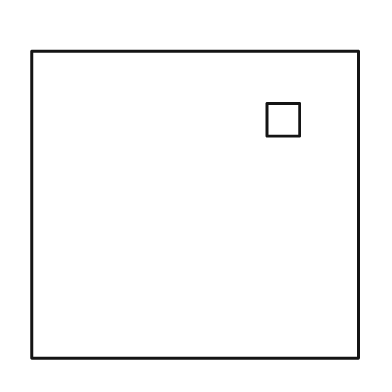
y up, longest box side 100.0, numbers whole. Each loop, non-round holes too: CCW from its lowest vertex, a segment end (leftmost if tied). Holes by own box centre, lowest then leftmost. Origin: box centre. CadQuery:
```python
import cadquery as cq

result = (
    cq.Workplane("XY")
    .moveTo(-50.0, -47.0)
    .lineTo(50.0, -47.0)
    .lineTo(50.0, 47.0)
    .lineTo(-50.0, 47.0)
    .close()
    .moveTo(22.0, 21.0)
    .lineTo(32.0, 21.0)
    .lineTo(32.0, 31.0)
    .lineTo(22.0, 31.0)
    .close()
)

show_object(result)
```